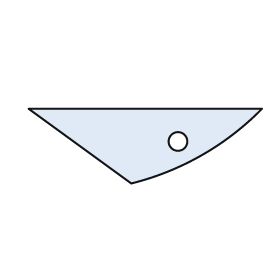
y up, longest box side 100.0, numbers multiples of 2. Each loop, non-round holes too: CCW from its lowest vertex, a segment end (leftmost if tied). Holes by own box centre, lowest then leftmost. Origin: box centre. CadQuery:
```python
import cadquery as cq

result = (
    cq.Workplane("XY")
    .moveTo(-6.0, -16.0)
    .threePointArc((24.0, -4.0), (50.0, 16.0))
    .lineTo(-50.0, 16.0)
    .close()
    .moveTo(14.0, 2.0)
    .circle(4.0)
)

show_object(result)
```